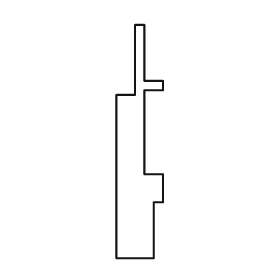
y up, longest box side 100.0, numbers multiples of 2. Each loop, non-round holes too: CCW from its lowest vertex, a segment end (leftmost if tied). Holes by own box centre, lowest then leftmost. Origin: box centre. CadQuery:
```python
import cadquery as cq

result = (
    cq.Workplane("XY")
    .moveTo(-10.0, -50.0)
    .lineTo(6.0, -50.0)
    .lineTo(6.0, -26.0)
    .lineTo(10.0, -26.0)
    .lineTo(10.0, -14.0)
    .lineTo(2.0, -14.0)
    .lineTo(2.0, 22.0)
    .lineTo(10.0, 22.0)
    .lineTo(10.0, 26.0)
    .lineTo(2.0, 26.0)
    .lineTo(2.0, 50.0)
    .lineTo(-2.0, 50.0)
    .lineTo(-2.0, 20.0)
    .lineTo(-10.0, 20.0)
    .close()
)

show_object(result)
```